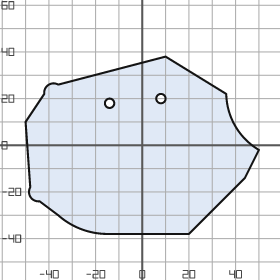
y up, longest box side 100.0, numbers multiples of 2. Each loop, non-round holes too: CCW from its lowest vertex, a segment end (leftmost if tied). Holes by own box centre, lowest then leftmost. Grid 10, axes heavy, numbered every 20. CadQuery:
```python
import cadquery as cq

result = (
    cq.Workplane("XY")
    .moveTo(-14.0, -38.0)
    .lineTo(20.0, -38.0)
    .lineTo(44.0, -14.0)
    .lineTo(50.0, -2.0)
    .threePointArc((40.0, 8.0), (36.0, 22.0))
    .lineTo(10.0, 38.0)
    .lineTo(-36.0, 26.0)
    .threePointArc((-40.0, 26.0), (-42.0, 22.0))
    .lineTo(-50.0, 10.0)
    .lineTo(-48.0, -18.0)
    .threePointArc((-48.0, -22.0), (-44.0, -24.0))
    .lineTo(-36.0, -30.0)
    .threePointArc((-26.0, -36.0), (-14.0, -38.0))
    .close()
    .moveTo(-14.0, 18.0)
    .circle(2.0)
    .moveTo(8.0, 20.0)
    .circle(2.0)
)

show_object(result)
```